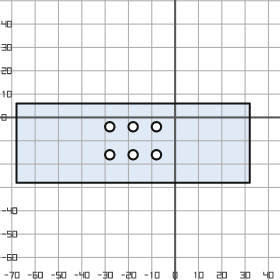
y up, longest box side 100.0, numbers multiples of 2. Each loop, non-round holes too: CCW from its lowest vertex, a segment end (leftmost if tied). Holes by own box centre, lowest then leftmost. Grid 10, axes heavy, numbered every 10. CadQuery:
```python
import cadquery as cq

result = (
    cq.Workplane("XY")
    .moveTo(-68.0, -28.0)
    .lineTo(32.0, -28.0)
    .lineTo(32.0, 6.0)
    .lineTo(-68.0, 6.0)
    .close()
    .moveTo(-28.0, -16.0)
    .circle(2.0)
    .moveTo(-18.0, -16.0)
    .circle(2.0)
    .moveTo(-8.0, -16.0)
    .circle(2.0)
    .moveTo(-28.0, -4.0)
    .circle(2.0)
    .moveTo(-18.0, -4.0)
    .circle(2.0)
    .moveTo(-8.0, -4.0)
    .circle(2.0)
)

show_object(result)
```